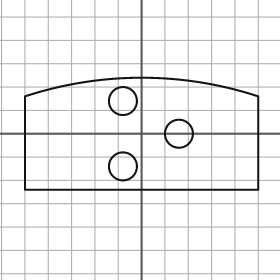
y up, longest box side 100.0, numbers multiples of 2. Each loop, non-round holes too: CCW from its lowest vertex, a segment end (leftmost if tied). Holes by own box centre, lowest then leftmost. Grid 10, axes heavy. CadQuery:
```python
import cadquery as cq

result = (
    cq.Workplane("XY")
    .moveTo(-50.0, -24.0)
    .lineTo(50.0, -24.0)
    .lineTo(50.0, 16.0)
    .threePointArc((0.0, 24.0), (-50.0, 16.0))
    .close()
    .moveTo(-8.0, -14.0)
    .circle(6.0)
    .moveTo(16.0, 0.0)
    .circle(6.0)
    .moveTo(-8.0, 14.0)
    .circle(6.0)
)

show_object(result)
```